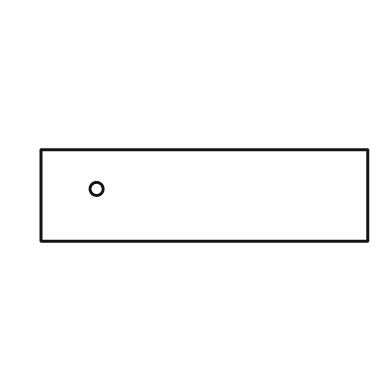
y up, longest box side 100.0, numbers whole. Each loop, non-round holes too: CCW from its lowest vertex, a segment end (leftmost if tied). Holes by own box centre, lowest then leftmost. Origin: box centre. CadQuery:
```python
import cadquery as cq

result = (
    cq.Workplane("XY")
    .moveTo(-50.0, -14.0)
    .lineTo(50.0, -14.0)
    .lineTo(50.0, 14.0)
    .lineTo(-50.0, 14.0)
    .close()
    .moveTo(-33.0, 2.0)
    .circle(2.0)
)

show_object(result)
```